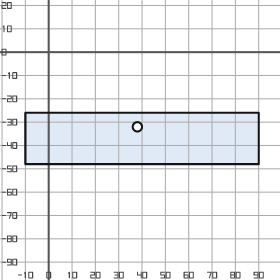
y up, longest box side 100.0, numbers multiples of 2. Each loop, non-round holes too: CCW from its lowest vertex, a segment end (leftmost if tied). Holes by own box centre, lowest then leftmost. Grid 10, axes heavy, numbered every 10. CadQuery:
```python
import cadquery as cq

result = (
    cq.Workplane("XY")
    .moveTo(-10.0, -48.0)
    .lineTo(90.0, -48.0)
    .lineTo(90.0, -26.0)
    .lineTo(-10.0, -26.0)
    .close()
    .moveTo(38.0, -32.0)
    .circle(2.0)
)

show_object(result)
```